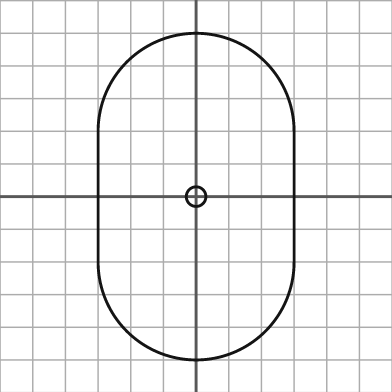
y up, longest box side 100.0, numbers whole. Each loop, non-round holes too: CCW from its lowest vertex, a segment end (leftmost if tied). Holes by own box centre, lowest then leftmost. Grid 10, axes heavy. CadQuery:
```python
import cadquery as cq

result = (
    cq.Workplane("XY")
    .moveTo(-30.0, -20.0)
    .threePointArc((0.0, -50.0), (30.0, -20.0))
    .lineTo(30.0, 20.0)
    .threePointArc((0.0, 50.0), (-30.0, 20.0))
    .close()
    .moveTo(0.0, 0.0)
    .circle(3.0)
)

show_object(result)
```